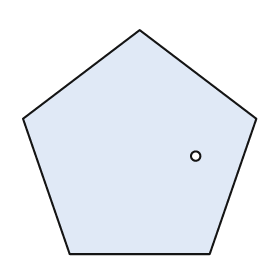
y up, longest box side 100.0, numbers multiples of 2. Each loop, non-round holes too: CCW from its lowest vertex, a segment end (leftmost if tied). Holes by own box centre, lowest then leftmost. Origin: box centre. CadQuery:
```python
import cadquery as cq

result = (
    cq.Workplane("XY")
    .moveTo(-30.0, -48.0)
    .lineTo(30.0, -48.0)
    .lineTo(50.0, 10.0)
    .lineTo(0.0, 48.0)
    .lineTo(-50.0, 10.0)
    .close()
    .moveTo(24.0, -6.0)
    .circle(2.0)
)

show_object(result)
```